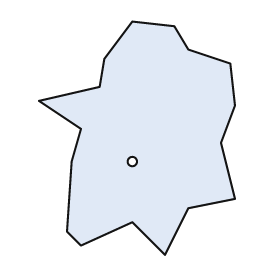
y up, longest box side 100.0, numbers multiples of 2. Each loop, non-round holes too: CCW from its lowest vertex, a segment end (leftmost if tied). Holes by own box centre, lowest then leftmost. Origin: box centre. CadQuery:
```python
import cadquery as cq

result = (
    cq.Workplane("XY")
    .moveTo(12.0, -50.0)
    .lineTo(22.0, -30.0)
    .lineTo(42.0, -26.0)
    .lineTo(36.0, -2.0)
    .lineTo(42.0, 14.0)
    .lineTo(40.0, 32.0)
    .lineTo(22.0, 38.0)
    .lineTo(16.0, 48.0)
    .lineTo(-2.0, 50.0)
    .lineTo(-14.0, 34.0)
    .lineTo(-16.0, 22.0)
    .lineTo(-42.0, 16.0)
    .lineTo(-24.0, 4.0)
    .lineTo(-28.0, -10.0)
    .lineTo(-30.0, -40.0)
    .lineTo(-24.0, -46.0)
    .lineTo(-2.0, -36.0)
    .close()
    .moveTo(-2.0, -10.0)
    .circle(2.0)
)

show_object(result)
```